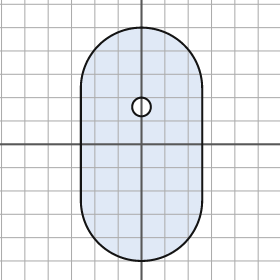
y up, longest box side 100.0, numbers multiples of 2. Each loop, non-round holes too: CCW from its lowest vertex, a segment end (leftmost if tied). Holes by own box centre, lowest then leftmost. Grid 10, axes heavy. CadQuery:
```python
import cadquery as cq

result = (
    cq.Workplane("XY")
    .moveTo(-26.0, -24.0)
    .threePointArc((0.0, -50.0), (26.0, -24.0))
    .lineTo(26.0, 24.0)
    .threePointArc((0.0, 50.0), (-26.0, 24.0))
    .close()
    .moveTo(0.0, 16.0)
    .circle(4.0)
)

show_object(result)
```